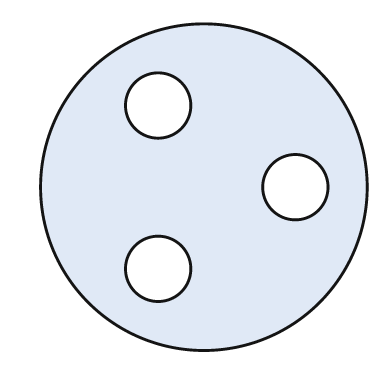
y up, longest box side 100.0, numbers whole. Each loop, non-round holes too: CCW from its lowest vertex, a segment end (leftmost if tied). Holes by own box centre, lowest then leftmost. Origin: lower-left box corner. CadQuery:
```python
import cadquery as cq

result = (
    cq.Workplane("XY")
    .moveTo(50.0, 50.0)
    .circle(50.0)
    .moveTo(36.0, 25.0)
    .circle(10.0)
    .moveTo(78.0, 50.0)
    .circle(10.0)
    .moveTo(36.0, 75.0)
    .circle(10.0)
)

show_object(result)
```